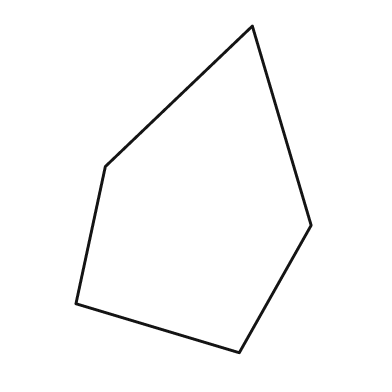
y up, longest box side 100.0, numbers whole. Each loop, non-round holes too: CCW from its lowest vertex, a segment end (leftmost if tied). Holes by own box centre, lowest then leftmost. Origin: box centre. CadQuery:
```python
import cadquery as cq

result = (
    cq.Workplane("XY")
    .moveTo(14.0, -50.0)
    .lineTo(36.0, -11.0)
    .lineTo(18.0, 50.0)
    .lineTo(-27.0, 7.0)
    .lineTo(-36.0, -35.0)
    .close()
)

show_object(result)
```